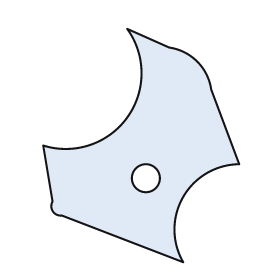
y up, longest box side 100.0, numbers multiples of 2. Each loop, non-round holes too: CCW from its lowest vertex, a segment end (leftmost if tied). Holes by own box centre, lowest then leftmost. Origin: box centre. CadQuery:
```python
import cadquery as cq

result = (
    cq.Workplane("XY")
    .moveTo(18.0, -50.0)
    .threePointArc((18.0, -22.0), (42.0, -8.0))
    .lineTo(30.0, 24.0)
    .threePointArc((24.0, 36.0), (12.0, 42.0))
    .lineTo(-6.0, 50.0)
    .threePointArc((-6.0, 12.0), (-42.0, 0.0))
    .lineTo(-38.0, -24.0)
    .threePointArc((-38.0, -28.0), (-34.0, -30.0))
    .close()
    .moveTo(2.0, -14.0)
    .circle(6.0)
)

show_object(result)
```